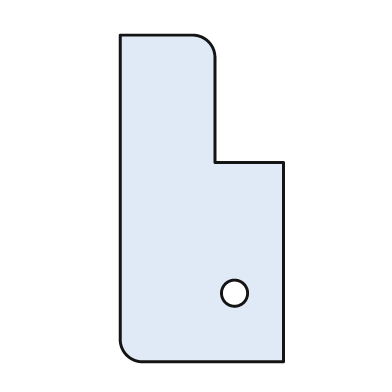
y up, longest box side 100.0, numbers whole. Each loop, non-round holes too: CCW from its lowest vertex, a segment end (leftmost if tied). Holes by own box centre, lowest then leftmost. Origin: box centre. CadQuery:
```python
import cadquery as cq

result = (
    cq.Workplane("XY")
    .moveTo(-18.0, -50.0)
    .lineTo(25.0, -50.0)
    .lineTo(25.0, 11.0)
    .lineTo(4.0, 11.0)
    .lineTo(4.0, 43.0)
    .threePointArc((2.0, 48.0), (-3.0, 50.0))
    .lineTo(-25.0, 50.0)
    .lineTo(-25.0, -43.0)
    .threePointArc((-23.0, -48.0), (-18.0, -50.0))
    .close()
    .moveTo(10.0, -29.0)
    .circle(4.0)
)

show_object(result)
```